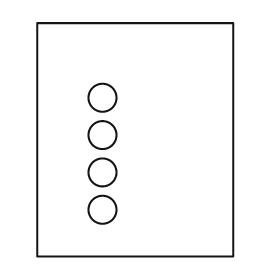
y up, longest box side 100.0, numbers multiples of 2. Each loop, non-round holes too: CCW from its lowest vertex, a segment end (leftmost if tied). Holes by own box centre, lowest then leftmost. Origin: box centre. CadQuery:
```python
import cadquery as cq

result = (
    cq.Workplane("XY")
    .moveTo(-42.0, -50.0)
    .lineTo(42.0, -50.0)
    .lineTo(42.0, 50.0)
    .lineTo(-42.0, 50.0)
    .close()
    .moveTo(-14.0, -30.0)
    .circle(6.0)
    .moveTo(-14.0, -14.0)
    .circle(6.0)
    .moveTo(-14.0, 2.0)
    .circle(6.0)
    .moveTo(-14.0, 18.0)
    .circle(6.0)
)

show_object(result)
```